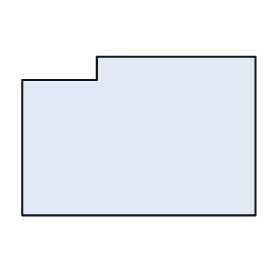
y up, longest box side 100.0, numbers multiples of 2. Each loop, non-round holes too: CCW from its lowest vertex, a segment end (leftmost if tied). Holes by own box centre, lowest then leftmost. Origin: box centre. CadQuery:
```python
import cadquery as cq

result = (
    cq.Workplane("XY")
    .moveTo(-50.0, -34.0)
    .lineTo(50.0, -34.0)
    .lineTo(50.0, 34.0)
    .lineTo(-18.0, 34.0)
    .lineTo(-18.0, 24.0)
    .lineTo(-50.0, 24.0)
    .close()
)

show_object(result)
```